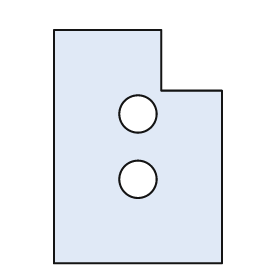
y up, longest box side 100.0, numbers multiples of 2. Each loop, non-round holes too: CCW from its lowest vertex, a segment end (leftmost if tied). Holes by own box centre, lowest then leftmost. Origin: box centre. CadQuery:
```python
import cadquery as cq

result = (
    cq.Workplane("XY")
    .moveTo(-36.0, -50.0)
    .lineTo(36.0, -50.0)
    .lineTo(36.0, 24.0)
    .lineTo(10.0, 24.0)
    .lineTo(10.0, 50.0)
    .lineTo(-36.0, 50.0)
    .close()
    .moveTo(0.0, -14.0)
    .circle(8.0)
    .moveTo(0.0, 14.0)
    .circle(8.0)
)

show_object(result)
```